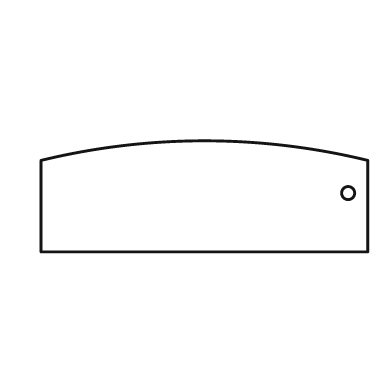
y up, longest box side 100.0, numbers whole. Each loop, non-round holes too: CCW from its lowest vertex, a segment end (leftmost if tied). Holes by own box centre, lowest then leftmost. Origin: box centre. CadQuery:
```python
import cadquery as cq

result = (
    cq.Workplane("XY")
    .moveTo(-50.0, -17.0)
    .lineTo(50.0, -17.0)
    .lineTo(50.0, 11.0)
    .threePointArc((0.0, 17.0), (-50.0, 11.0))
    .close()
    .moveTo(44.0, 1.0)
    .circle(2.0)
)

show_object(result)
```